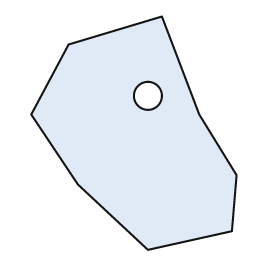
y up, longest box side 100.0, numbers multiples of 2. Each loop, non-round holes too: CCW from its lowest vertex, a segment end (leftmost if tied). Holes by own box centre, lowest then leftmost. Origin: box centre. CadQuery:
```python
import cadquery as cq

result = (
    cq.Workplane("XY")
    .moveTo(6.0, -50.0)
    .lineTo(42.0, -42.0)
    .lineTo(44.0, -18.0)
    .lineTo(28.0, 8.0)
    .lineTo(12.0, 50.0)
    .lineTo(-28.0, 38.0)
    .lineTo(-44.0, 8.0)
    .lineTo(-24.0, -22.0)
    .close()
    .moveTo(6.0, 16.0)
    .circle(6.0)
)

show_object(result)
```